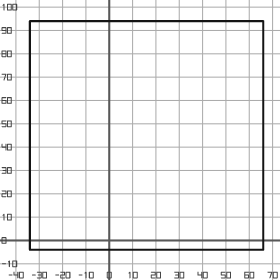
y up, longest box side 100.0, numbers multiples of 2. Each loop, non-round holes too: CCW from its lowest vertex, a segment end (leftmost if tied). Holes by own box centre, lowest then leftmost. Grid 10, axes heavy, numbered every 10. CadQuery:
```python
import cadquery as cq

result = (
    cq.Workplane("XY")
    .moveTo(-34.0, -4.0)
    .lineTo(66.0, -4.0)
    .lineTo(66.0, 94.0)
    .lineTo(-34.0, 94.0)
    .close()
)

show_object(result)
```